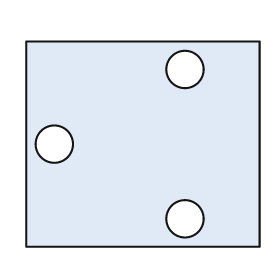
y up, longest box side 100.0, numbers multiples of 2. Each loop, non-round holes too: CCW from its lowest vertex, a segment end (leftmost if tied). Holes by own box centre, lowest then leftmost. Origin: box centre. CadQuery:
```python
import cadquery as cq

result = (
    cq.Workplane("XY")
    .moveTo(-50.0, -44.0)
    .lineTo(50.0, -44.0)
    .lineTo(50.0, 44.0)
    .lineTo(-50.0, 44.0)
    .close()
    .moveTo(18.0, -32.0)
    .circle(8.0)
    .moveTo(-38.0, 0.0)
    .circle(8.0)
    .moveTo(18.0, 32.0)
    .circle(8.0)
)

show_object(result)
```